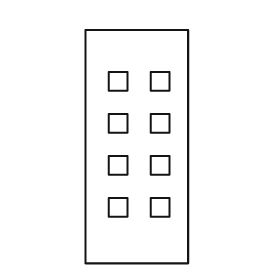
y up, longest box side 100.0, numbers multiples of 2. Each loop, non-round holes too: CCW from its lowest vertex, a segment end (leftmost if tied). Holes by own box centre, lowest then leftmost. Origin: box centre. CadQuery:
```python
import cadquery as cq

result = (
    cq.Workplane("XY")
    .moveTo(-22.0, -50.0)
    .lineTo(22.0, -50.0)
    .lineTo(22.0, 50.0)
    .lineTo(-22.0, 50.0)
    .close()
    .moveTo(-12.0, -30.0)
    .lineTo(-4.0, -30.0)
    .lineTo(-4.0, -22.0)
    .lineTo(-12.0, -22.0)
    .close()
    .moveTo(6.0, -30.0)
    .lineTo(14.0, -30.0)
    .lineTo(14.0, -22.0)
    .lineTo(6.0, -22.0)
    .close()
    .moveTo(-12.0, -12.0)
    .lineTo(-4.0, -12.0)
    .lineTo(-4.0, -4.0)
    .lineTo(-12.0, -4.0)
    .close()
    .moveTo(6.0, -12.0)
    .lineTo(14.0, -12.0)
    .lineTo(14.0, -4.0)
    .lineTo(6.0, -4.0)
    .close()
    .moveTo(-12.0, 6.0)
    .lineTo(-4.0, 6.0)
    .lineTo(-4.0, 14.0)
    .lineTo(-12.0, 14.0)
    .close()
    .moveTo(6.0, 6.0)
    .lineTo(14.0, 6.0)
    .lineTo(14.0, 14.0)
    .lineTo(6.0, 14.0)
    .close()
    .moveTo(-12.0, 24.0)
    .lineTo(-4.0, 24.0)
    .lineTo(-4.0, 32.0)
    .lineTo(-12.0, 32.0)
    .close()
    .moveTo(6.0, 24.0)
    .lineTo(14.0, 24.0)
    .lineTo(14.0, 32.0)
    .lineTo(6.0, 32.0)
    .close()
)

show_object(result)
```